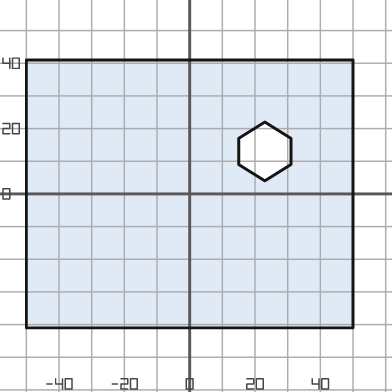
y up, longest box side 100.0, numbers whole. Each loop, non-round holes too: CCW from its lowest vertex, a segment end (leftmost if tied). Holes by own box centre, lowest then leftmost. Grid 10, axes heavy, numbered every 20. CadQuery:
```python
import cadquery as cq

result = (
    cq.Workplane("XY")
    .moveTo(-50.0, -41.0)
    .lineTo(50.0, -41.0)
    .lineTo(50.0, 41.0)
    .lineTo(-50.0, 41.0)
    .close()
    .moveTo(23.0, 4.0)
    .lineTo(31.0, 9.0)
    .lineTo(31.0, 17.0)
    .lineTo(23.0, 22.0)
    .lineTo(15.0, 17.0)
    .lineTo(15.0, 9.0)
    .close()
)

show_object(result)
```